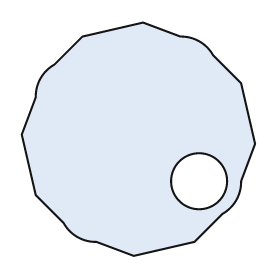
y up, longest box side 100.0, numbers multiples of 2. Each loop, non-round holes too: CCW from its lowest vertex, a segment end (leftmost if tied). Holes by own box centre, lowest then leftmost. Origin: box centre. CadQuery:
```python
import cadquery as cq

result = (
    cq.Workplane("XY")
    .moveTo(-2.0, -50.0)
    .lineTo(24.0, -44.0)
    .lineTo(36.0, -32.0)
    .threePointArc((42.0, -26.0), (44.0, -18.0))
    .lineTo(50.0, -2.0)
    .lineTo(44.0, 24.0)
    .lineTo(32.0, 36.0)
    .threePointArc((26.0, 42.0), (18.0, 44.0))
    .lineTo(2.0, 50.0)
    .lineTo(-24.0, 44.0)
    .lineTo(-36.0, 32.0)
    .threePointArc((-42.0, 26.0), (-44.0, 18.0))
    .lineTo(-50.0, 2.0)
    .lineTo(-44.0, -24.0)
    .lineTo(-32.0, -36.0)
    .threePointArc((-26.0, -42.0), (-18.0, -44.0))
    .close()
    .moveTo(26.0, -18.0)
    .circle(12.0)
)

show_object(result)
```